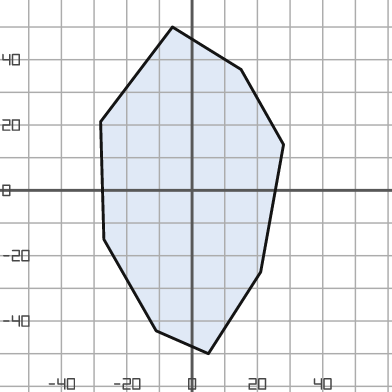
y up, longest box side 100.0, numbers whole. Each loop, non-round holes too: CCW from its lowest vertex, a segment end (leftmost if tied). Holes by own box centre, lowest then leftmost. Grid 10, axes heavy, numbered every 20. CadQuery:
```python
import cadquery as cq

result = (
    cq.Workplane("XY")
    .moveTo(5.0, -50.0)
    .lineTo(21.0, -25.0)
    .lineTo(28.0, 14.0)
    .lineTo(15.0, 37.0)
    .lineTo(-6.0, 50.0)
    .lineTo(-28.0, 21.0)
    .lineTo(-27.0, -15.0)
    .lineTo(-11.0, -43.0)
    .close()
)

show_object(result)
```